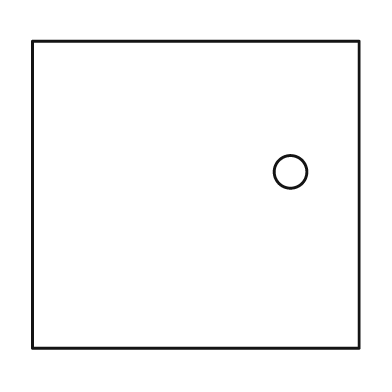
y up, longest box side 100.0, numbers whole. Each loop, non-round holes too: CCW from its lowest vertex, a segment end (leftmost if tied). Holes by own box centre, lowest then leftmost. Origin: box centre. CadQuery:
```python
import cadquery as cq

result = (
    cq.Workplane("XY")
    .moveTo(-50.0, -47.0)
    .lineTo(50.0, -47.0)
    .lineTo(50.0, 47.0)
    .lineTo(-50.0, 47.0)
    .close()
    .moveTo(29.0, 7.0)
    .circle(5.0)
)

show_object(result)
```